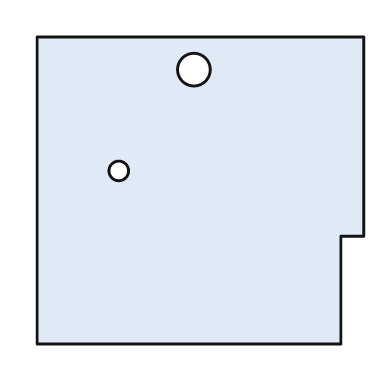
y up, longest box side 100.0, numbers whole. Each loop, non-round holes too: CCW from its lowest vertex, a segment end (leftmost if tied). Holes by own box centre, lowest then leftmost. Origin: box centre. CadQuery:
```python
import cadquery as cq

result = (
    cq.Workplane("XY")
    .moveTo(-50.0, -47.0)
    .lineTo(43.0, -47.0)
    .lineTo(43.0, -14.0)
    .lineTo(50.0, -14.0)
    .lineTo(50.0, 47.0)
    .lineTo(-50.0, 47.0)
    .close()
    .moveTo(-25.0, 6.0)
    .circle(3.0)
    .moveTo(-2.0, 37.0)
    .circle(5.0)
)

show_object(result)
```